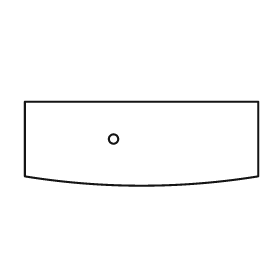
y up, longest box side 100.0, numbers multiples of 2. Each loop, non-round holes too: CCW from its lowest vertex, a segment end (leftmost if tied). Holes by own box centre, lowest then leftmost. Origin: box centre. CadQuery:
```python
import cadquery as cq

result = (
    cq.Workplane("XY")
    .moveTo(-50.0, -14.0)
    .threePointArc((0.0, -18.0), (50.0, -14.0))
    .lineTo(50.0, 18.0)
    .lineTo(-50.0, 18.0)
    .close()
    .moveTo(-12.0, 2.0)
    .circle(2.0)
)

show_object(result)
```